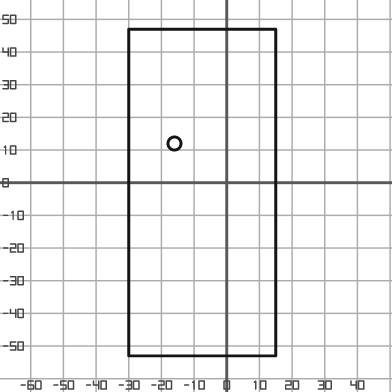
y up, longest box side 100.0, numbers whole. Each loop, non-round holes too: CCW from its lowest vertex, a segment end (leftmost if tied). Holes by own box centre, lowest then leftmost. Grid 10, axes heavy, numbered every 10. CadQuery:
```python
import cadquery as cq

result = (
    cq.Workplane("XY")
    .moveTo(-30.0, -53.0)
    .lineTo(15.0, -53.0)
    .lineTo(15.0, 47.0)
    .lineTo(-30.0, 47.0)
    .close()
    .moveTo(-16.0, 12.0)
    .circle(2.0)
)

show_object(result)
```